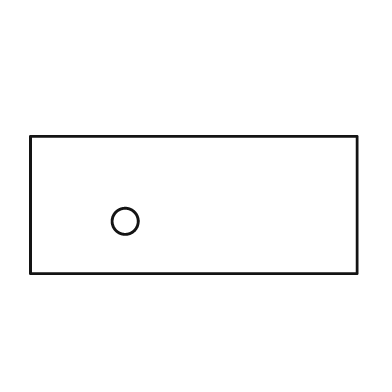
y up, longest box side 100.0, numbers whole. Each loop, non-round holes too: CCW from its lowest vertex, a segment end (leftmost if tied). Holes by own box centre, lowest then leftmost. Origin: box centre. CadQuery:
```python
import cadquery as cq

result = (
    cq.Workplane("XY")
    .moveTo(-50.0, -21.0)
    .lineTo(50.0, -21.0)
    .lineTo(50.0, 21.0)
    .lineTo(-50.0, 21.0)
    .close()
    .moveTo(-21.0, -5.0)
    .circle(4.0)
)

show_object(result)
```